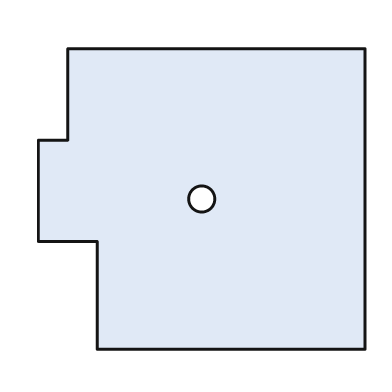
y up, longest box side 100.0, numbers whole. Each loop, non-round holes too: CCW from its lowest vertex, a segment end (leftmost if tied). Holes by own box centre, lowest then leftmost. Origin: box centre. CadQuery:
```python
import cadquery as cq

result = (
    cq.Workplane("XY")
    .moveTo(-32.0, -46.0)
    .lineTo(50.0, -46.0)
    .lineTo(50.0, 46.0)
    .lineTo(-41.0, 46.0)
    .lineTo(-41.0, 18.0)
    .lineTo(-50.0, 18.0)
    .lineTo(-50.0, -13.0)
    .lineTo(-32.0, -13.0)
    .close()
    .moveTo(0.0, 0.0)
    .circle(4.0)
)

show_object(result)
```